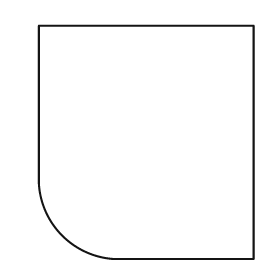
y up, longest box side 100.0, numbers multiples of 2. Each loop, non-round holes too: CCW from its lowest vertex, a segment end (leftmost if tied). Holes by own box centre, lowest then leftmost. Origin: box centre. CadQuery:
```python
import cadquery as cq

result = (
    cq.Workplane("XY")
    .moveTo(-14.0, -50.0)
    .lineTo(46.0, -50.0)
    .lineTo(46.0, 50.0)
    .lineTo(-46.0, 50.0)
    .lineTo(-46.0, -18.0)
    .threePointArc((-36.0, -40.0), (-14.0, -50.0))
    .close()
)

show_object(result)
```